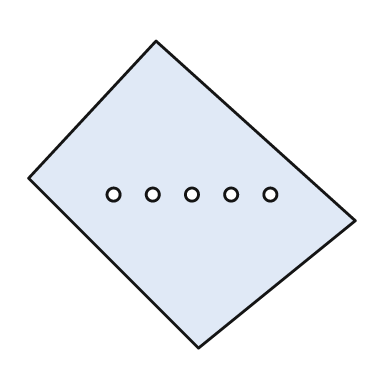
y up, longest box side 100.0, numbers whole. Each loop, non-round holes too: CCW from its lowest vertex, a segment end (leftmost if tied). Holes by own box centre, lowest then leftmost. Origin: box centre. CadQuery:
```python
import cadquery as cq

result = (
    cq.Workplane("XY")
    .moveTo(2.0, -47.0)
    .lineTo(50.0, -8.0)
    .lineTo(-11.0, 47.0)
    .lineTo(-50.0, 5.0)
    .close()
    .moveTo(-24.0, 0.0)
    .circle(2.0)
    .moveTo(-12.0, 0.0)
    .circle(2.0)
    .moveTo(0.0, 0.0)
    .circle(2.0)
    .moveTo(12.0, 0.0)
    .circle(2.0)
    .moveTo(24.0, 0.0)
    .circle(2.0)
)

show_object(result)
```